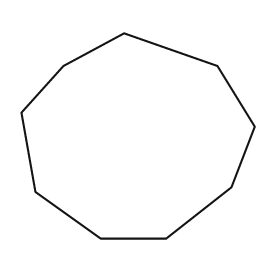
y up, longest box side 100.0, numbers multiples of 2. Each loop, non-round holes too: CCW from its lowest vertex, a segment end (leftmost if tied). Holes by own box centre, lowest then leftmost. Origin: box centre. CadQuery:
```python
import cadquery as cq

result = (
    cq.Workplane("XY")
    .moveTo(-16.0, -44.0)
    .lineTo(12.0, -44.0)
    .lineTo(40.0, -22.0)
    .lineTo(50.0, 4.0)
    .lineTo(34.0, 30.0)
    .lineTo(-6.0, 44.0)
    .lineTo(-32.0, 30.0)
    .lineTo(-50.0, 10.0)
    .lineTo(-44.0, -24.0)
    .close()
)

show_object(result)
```